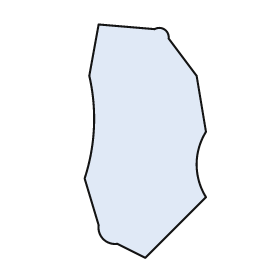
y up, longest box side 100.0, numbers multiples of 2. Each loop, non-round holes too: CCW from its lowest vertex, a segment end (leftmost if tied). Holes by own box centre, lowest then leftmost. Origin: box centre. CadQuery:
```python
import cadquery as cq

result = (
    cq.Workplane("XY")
    .moveTo(0.0, -50.0)
    .lineTo(26.0, -24.0)
    .threePointArc((22.0, -10.0), (26.0, 4.0))
    .lineTo(22.0, 28.0)
    .lineTo(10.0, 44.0)
    .threePointArc((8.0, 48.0), (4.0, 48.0))
    .lineTo(-20.0, 50.0)
    .lineTo(-24.0, 28.0)
    .threePointArc((-22.0, 6.0), (-26.0, -16.0))
    .lineTo(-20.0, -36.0)
    .threePointArc((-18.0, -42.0), (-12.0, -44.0))
    .close()
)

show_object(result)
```